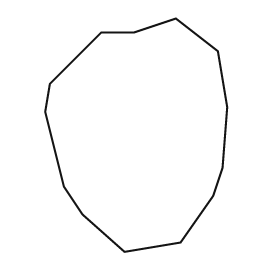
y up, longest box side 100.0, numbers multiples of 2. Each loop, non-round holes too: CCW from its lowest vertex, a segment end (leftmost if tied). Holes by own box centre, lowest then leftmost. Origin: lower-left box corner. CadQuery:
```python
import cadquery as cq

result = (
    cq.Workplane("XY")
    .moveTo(34.0, 0.0)
    .lineTo(58.0, 4.0)
    .lineTo(72.0, 24.0)
    .lineTo(76.0, 36.0)
    .lineTo(78.0, 62.0)
    .lineTo(74.0, 86.0)
    .lineTo(56.0, 100.0)
    .lineTo(38.0, 94.0)
    .lineTo(24.0, 94.0)
    .lineTo(2.0, 72.0)
    .lineTo(0.0, 60.0)
    .lineTo(8.0, 28.0)
    .lineTo(16.0, 16.0)
    .close()
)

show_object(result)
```